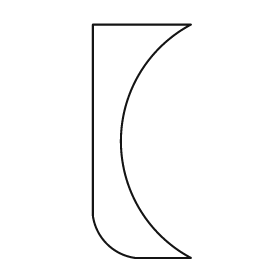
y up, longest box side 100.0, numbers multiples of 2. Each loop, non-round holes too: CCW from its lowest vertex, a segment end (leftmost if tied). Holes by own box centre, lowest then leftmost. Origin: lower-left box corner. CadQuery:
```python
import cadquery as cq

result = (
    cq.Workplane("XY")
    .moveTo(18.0, 0.0)
    .lineTo(42.0, 0.0)
    .threePointArc((12.0, 50.0), (42.0, 100.0))
    .lineTo(0.0, 100.0)
    .lineTo(0.0, 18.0)
    .threePointArc((6.0, 6.0), (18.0, 0.0))
    .close()
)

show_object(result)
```